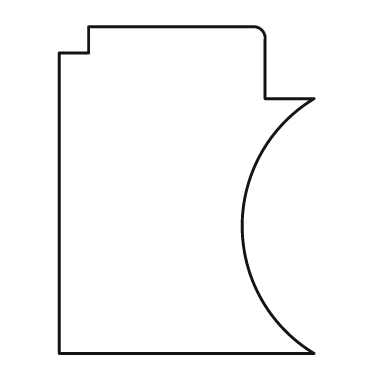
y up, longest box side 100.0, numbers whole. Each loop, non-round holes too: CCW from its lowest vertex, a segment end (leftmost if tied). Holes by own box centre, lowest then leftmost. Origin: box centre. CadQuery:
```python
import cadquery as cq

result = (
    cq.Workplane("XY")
    .moveTo(-39.0, -50.0)
    .lineTo(39.0, -50.0)
    .threePointArc((17.0, -11.0), (39.0, 28.0))
    .lineTo(24.0, 28.0)
    .lineTo(24.0, 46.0)
    .threePointArc((23.0, 49.0), (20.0, 50.0))
    .lineTo(-30.0, 50.0)
    .lineTo(-30.0, 42.0)
    .lineTo(-39.0, 42.0)
    .close()
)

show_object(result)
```